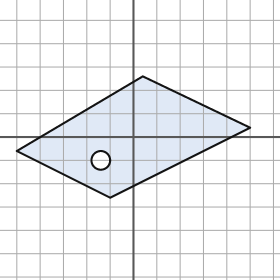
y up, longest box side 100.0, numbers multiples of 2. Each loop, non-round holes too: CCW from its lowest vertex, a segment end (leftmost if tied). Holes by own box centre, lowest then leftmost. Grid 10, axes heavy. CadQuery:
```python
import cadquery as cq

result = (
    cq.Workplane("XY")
    .moveTo(-10.0, -26.0)
    .lineTo(50.0, 4.0)
    .lineTo(4.0, 26.0)
    .lineTo(-50.0, -6.0)
    .close()
    .moveTo(-14.0, -10.0)
    .circle(4.0)
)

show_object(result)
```